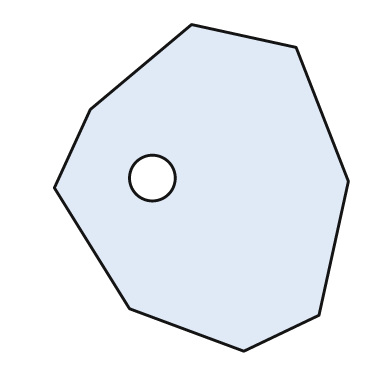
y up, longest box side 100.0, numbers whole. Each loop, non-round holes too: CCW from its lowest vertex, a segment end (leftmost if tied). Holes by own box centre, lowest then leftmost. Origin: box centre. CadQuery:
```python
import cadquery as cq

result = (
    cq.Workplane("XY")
    .moveTo(13.0, -50.0)
    .lineTo(36.0, -39.0)
    .lineTo(45.0, 2.0)
    .lineTo(29.0, 43.0)
    .lineTo(-3.0, 50.0)
    .lineTo(-34.0, 24.0)
    .lineTo(-45.0, 0.0)
    .lineTo(-22.0, -37.0)
    .close()
    .moveTo(-15.0, 3.0)
    .circle(7.0)
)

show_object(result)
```